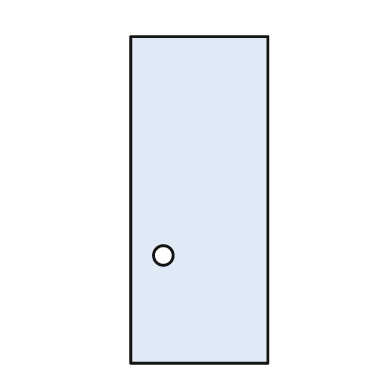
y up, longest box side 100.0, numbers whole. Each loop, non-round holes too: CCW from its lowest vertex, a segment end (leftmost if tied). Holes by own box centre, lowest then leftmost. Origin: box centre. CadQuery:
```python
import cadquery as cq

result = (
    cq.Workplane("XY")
    .moveTo(-21.0, -50.0)
    .lineTo(21.0, -50.0)
    .lineTo(21.0, 50.0)
    .lineTo(-21.0, 50.0)
    .close()
    .moveTo(-11.0, -17.0)
    .circle(3.0)
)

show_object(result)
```